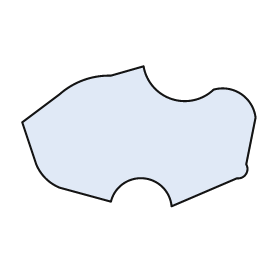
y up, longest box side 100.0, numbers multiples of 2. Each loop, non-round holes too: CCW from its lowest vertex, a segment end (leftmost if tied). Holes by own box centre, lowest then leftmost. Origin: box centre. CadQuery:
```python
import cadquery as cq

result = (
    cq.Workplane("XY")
    .moveTo(14.0, -30.0)
    .lineTo(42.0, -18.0)
    .threePointArc((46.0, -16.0), (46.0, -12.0))
    .lineTo(50.0, 8.0)
    .threePointArc((44.0, 18.0), (32.0, 20.0))
    .threePointArc((14.0, 16.0), (2.0, 30.0))
    .lineTo(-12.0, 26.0)
    .threePointArc((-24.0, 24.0), (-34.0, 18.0))
    .lineTo(-50.0, 6.0)
    .lineTo(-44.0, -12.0)
    .threePointArc((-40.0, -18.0), (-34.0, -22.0))
    .lineTo(-12.0, -28.0)
    .threePointArc((2.0, -18.0), (14.0, -30.0))
    .close()
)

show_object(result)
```